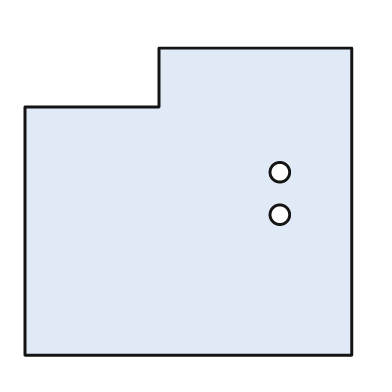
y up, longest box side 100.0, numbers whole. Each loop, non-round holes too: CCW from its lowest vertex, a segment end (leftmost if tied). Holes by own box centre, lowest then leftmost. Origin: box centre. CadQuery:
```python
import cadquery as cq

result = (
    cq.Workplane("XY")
    .moveTo(-50.0, -47.0)
    .lineTo(50.0, -47.0)
    .lineTo(50.0, 47.0)
    .lineTo(-9.0, 47.0)
    .lineTo(-9.0, 29.0)
    .lineTo(-50.0, 29.0)
    .close()
    .moveTo(28.0, -4.0)
    .circle(3.0)
    .moveTo(28.0, 9.0)
    .circle(3.0)
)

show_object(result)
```